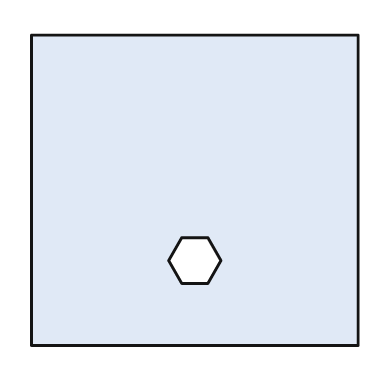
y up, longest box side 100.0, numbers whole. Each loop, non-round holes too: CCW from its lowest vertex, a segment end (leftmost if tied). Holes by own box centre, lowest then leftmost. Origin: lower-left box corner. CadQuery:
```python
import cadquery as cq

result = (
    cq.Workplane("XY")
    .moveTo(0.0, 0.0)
    .lineTo(100.0, 0.0)
    .lineTo(100.0, 95.0)
    .lineTo(0.0, 95.0)
    .close()
    .moveTo(46.0, 19.0)
    .lineTo(54.0, 19.0)
    .lineTo(58.0, 26.0)
    .lineTo(54.0, 33.0)
    .lineTo(46.0, 33.0)
    .lineTo(42.0, 26.0)
    .close()
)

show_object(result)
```